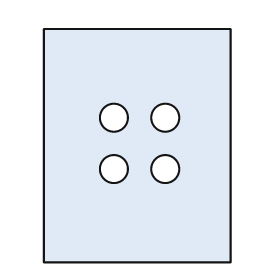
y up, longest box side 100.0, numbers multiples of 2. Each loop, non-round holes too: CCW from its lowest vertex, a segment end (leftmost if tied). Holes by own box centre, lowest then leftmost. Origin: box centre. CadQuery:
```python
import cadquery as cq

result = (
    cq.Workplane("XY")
    .moveTo(-40.0, -50.0)
    .lineTo(40.0, -50.0)
    .lineTo(40.0, 50.0)
    .lineTo(-40.0, 50.0)
    .close()
    .moveTo(-10.0, -10.0)
    .circle(6.0)
    .moveTo(12.0, -10.0)
    .circle(6.0)
    .moveTo(-10.0, 12.0)
    .circle(6.0)
    .moveTo(12.0, 12.0)
    .circle(6.0)
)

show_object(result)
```